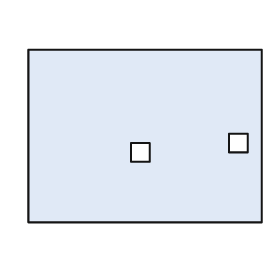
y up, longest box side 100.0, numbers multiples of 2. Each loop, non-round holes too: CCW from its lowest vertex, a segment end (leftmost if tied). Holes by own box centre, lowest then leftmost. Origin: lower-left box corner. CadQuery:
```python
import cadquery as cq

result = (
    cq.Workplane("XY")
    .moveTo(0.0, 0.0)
    .lineTo(100.0, 0.0)
    .lineTo(100.0, 74.0)
    .lineTo(0.0, 74.0)
    .close()
    .moveTo(44.0, 26.0)
    .lineTo(52.0, 26.0)
    .lineTo(52.0, 34.0)
    .lineTo(44.0, 34.0)
    .close()
    .moveTo(86.0, 30.0)
    .lineTo(94.0, 30.0)
    .lineTo(94.0, 38.0)
    .lineTo(86.0, 38.0)
    .close()
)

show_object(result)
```